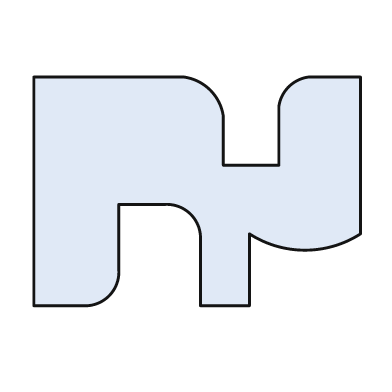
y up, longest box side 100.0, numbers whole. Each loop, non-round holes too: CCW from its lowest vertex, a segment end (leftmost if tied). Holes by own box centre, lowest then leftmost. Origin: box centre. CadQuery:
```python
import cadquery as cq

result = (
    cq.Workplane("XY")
    .moveTo(-50.0, -35.0)
    .lineTo(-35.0, -35.0)
    .threePointArc((-27.0, -32.0), (-24.0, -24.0))
    .lineTo(-24.0, -4.0)
    .lineTo(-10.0, -4.0)
    .threePointArc((-2.0, -7.0), (1.0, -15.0))
    .lineTo(1.0, -35.0)
    .lineTo(16.0, -35.0)
    .lineTo(16.0, -13.0)
    .threePointArc((33.0, -18.0), (50.0, -13.0))
    .lineTo(50.0, 35.0)
    .lineTo(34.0, 35.0)
    .threePointArc((28.0, 32.0), (25.0, 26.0))
    .lineTo(25.0, 8.0)
    .lineTo(8.0, 8.0)
    .lineTo(8.0, 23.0)
    .threePointArc((4.0, 31.0), (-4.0, 35.0))
    .lineTo(-50.0, 35.0)
    .close()
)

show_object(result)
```